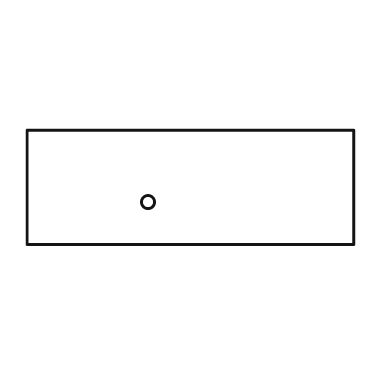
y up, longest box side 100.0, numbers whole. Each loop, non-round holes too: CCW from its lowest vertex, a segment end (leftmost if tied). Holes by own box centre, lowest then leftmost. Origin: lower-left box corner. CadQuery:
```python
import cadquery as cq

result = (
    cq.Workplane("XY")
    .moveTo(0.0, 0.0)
    .lineTo(100.0, 0.0)
    .lineTo(100.0, 35.0)
    .lineTo(0.0, 35.0)
    .close()
    .moveTo(37.0, 13.0)
    .circle(2.0)
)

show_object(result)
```